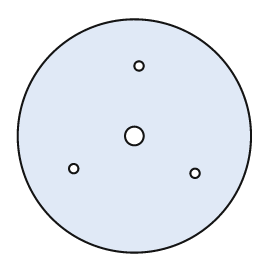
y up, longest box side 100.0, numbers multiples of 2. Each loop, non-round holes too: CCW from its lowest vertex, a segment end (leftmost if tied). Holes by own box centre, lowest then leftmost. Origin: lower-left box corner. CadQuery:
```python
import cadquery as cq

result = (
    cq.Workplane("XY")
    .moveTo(50.0, 50.0)
    .circle(50.0)
    .moveTo(76.0, 34.0)
    .circle(2.0)
    .moveTo(24.0, 36.0)
    .circle(2.0)
    .moveTo(50.0, 50.0)
    .circle(4.0)
    .moveTo(52.0, 80.0)
    .circle(2.0)
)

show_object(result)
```